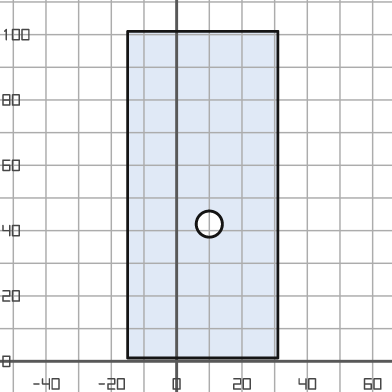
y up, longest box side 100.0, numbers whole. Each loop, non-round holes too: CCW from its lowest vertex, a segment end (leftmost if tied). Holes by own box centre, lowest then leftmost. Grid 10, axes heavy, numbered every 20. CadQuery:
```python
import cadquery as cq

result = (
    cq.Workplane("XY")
    .moveTo(-15.0, 1.0)
    .lineTo(31.0, 1.0)
    .lineTo(31.0, 101.0)
    .lineTo(-15.0, 101.0)
    .close()
    .moveTo(10.0, 42.0)
    .circle(4.0)
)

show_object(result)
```